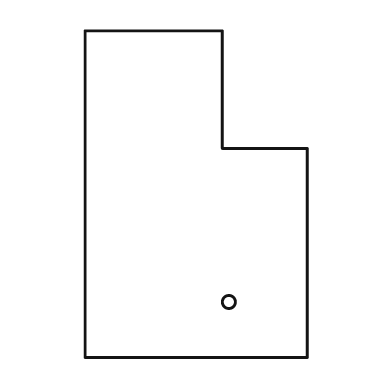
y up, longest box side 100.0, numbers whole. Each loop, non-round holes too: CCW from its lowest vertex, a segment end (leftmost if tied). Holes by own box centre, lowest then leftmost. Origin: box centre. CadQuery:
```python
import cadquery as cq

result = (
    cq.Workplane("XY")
    .moveTo(-34.0, -50.0)
    .lineTo(34.0, -50.0)
    .lineTo(34.0, 14.0)
    .lineTo(8.0, 14.0)
    .lineTo(8.0, 50.0)
    .lineTo(-34.0, 50.0)
    .close()
    .moveTo(10.0, -33.0)
    .circle(2.0)
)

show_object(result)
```